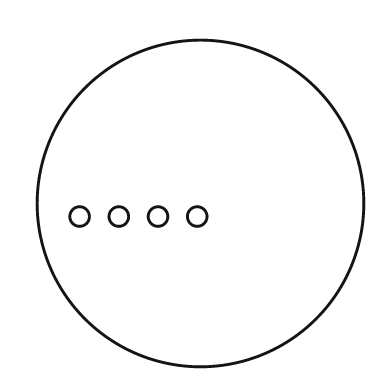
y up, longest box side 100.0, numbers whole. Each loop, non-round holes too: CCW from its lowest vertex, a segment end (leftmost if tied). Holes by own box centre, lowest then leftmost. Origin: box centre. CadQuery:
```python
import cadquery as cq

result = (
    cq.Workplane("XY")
    .moveTo(0.0, 0.0)
    .circle(50.0)
    .moveTo(-37.0, -4.0)
    .circle(3.0)
    .moveTo(-25.0, -4.0)
    .circle(3.0)
    .moveTo(-13.0, -4.0)
    .circle(3.0)
    .moveTo(-1.0, -4.0)
    .circle(3.0)
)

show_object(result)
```